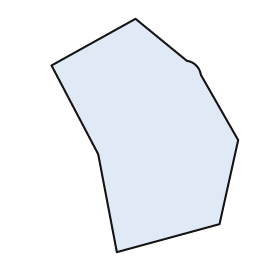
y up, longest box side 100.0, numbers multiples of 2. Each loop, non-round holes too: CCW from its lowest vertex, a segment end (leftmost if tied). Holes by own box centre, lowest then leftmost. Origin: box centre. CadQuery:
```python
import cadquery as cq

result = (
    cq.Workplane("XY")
    .moveTo(-12.0, -50.0)
    .lineTo(32.0, -38.0)
    .lineTo(40.0, -2.0)
    .lineTo(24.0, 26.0)
    .threePointArc((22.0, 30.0), (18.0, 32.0))
    .lineTo(-4.0, 50.0)
    .lineTo(-40.0, 30.0)
    .lineTo(-20.0, -8.0)
    .close()
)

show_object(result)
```